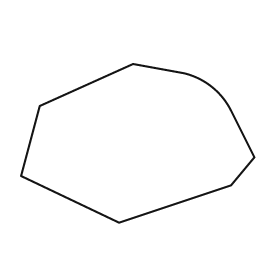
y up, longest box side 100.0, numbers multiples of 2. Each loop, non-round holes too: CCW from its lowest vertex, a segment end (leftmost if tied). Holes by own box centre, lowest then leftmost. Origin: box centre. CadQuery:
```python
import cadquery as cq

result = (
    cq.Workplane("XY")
    .moveTo(-8.0, -34.0)
    .lineTo(40.0, -18.0)
    .lineTo(50.0, -6.0)
    .lineTo(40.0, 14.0)
    .threePointArc((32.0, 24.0), (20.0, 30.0))
    .lineTo(-2.0, 34.0)
    .lineTo(-42.0, 16.0)
    .lineTo(-50.0, -14.0)
    .close()
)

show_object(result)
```